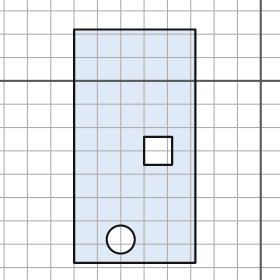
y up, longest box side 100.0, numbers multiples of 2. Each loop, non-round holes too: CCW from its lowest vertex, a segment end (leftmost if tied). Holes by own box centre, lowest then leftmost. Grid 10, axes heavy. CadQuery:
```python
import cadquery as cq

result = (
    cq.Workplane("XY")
    .moveTo(-80.0, -78.0)
    .lineTo(-28.0, -78.0)
    .lineTo(-28.0, 22.0)
    .lineTo(-80.0, 22.0)
    .close()
    .moveTo(-60.0, -68.0)
    .circle(6.0)
    .moveTo(-50.0, -36.0)
    .lineTo(-38.0, -36.0)
    .lineTo(-38.0, -24.0)
    .lineTo(-50.0, -24.0)
    .close()
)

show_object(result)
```